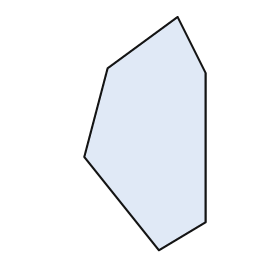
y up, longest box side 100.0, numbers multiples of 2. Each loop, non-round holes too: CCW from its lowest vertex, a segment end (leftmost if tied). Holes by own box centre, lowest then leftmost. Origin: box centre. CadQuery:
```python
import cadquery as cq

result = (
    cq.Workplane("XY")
    .moveTo(6.0, -50.0)
    .lineTo(26.0, -38.0)
    .lineTo(26.0, 26.0)
    .lineTo(14.0, 50.0)
    .lineTo(-16.0, 28.0)
    .lineTo(-26.0, -10.0)
    .close()
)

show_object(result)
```